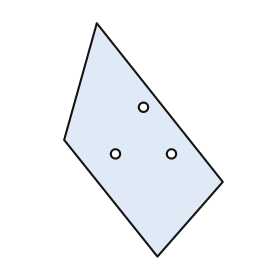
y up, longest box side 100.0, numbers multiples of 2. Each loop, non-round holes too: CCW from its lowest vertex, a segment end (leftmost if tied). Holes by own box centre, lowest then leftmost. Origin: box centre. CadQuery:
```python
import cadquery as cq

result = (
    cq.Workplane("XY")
    .moveTo(6.0, -50.0)
    .lineTo(34.0, -18.0)
    .lineTo(-20.0, 50.0)
    .lineTo(-34.0, 0.0)
    .close()
    .moveTo(-12.0, -6.0)
    .circle(2.0)
    .moveTo(12.0, -6.0)
    .circle(2.0)
    .moveTo(0.0, 14.0)
    .circle(2.0)
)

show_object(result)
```